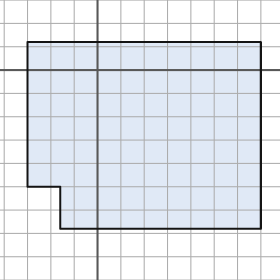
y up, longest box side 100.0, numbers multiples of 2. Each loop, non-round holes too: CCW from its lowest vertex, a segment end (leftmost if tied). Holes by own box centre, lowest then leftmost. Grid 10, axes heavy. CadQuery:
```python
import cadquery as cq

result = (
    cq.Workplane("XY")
    .moveTo(-16.0, -68.0)
    .lineTo(70.0, -68.0)
    .lineTo(70.0, 12.0)
    .lineTo(-30.0, 12.0)
    .lineTo(-30.0, -50.0)
    .lineTo(-16.0, -50.0)
    .close()
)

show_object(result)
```